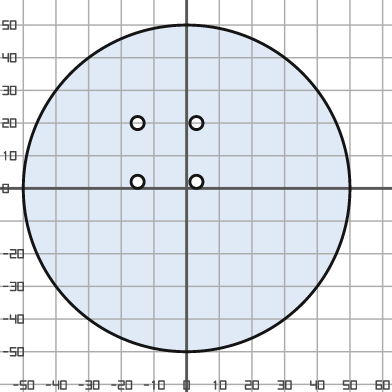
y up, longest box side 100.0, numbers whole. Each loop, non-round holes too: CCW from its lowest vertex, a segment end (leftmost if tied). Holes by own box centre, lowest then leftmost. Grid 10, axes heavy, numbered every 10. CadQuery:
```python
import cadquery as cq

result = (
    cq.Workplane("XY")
    .moveTo(0.0, 0.0)
    .circle(50.0)
    .moveTo(-15.0, 2.0)
    .circle(2.0)
    .moveTo(3.0, 2.0)
    .circle(2.0)
    .moveTo(-15.0, 20.0)
    .circle(2.0)
    .moveTo(3.0, 20.0)
    .circle(2.0)
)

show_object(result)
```